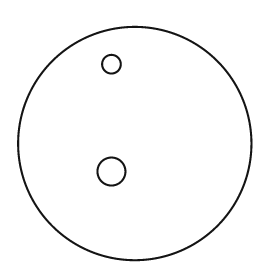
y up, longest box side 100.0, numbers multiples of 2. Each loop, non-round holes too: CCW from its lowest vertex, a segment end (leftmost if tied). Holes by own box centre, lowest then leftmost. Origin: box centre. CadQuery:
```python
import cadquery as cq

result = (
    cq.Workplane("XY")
    .moveTo(0.0, 0.0)
    .circle(50.0)
    .moveTo(-10.0, -12.0)
    .circle(6.0)
    .moveTo(-10.0, 34.0)
    .circle(4.0)
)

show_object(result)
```